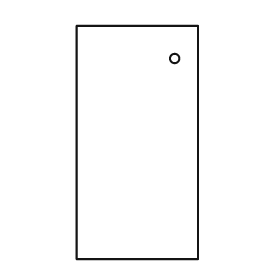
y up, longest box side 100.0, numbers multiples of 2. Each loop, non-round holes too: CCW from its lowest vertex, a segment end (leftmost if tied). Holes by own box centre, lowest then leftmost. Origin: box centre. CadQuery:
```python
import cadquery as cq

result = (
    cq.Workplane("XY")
    .moveTo(-26.0, -50.0)
    .lineTo(26.0, -50.0)
    .lineTo(26.0, 50.0)
    .lineTo(-26.0, 50.0)
    .close()
    .moveTo(16.0, 36.0)
    .circle(2.0)
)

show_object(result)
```